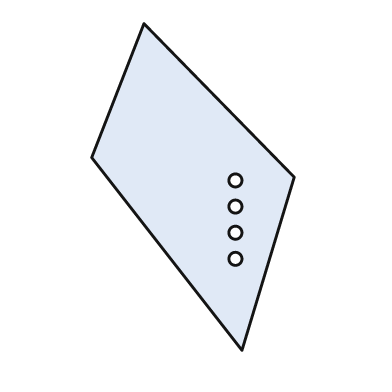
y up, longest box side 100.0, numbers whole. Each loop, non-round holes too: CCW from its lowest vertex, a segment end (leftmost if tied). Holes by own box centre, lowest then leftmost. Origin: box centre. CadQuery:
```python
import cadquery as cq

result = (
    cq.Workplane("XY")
    .moveTo(15.0, -50.0)
    .lineTo(31.0, 3.0)
    .lineTo(-15.0, 50.0)
    .lineTo(-31.0, 9.0)
    .close()
    .moveTo(13.0, -22.0)
    .circle(2.0)
    .moveTo(13.0, -14.0)
    .circle(2.0)
    .moveTo(13.0, -6.0)
    .circle(2.0)
    .moveTo(13.0, 2.0)
    .circle(2.0)
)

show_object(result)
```